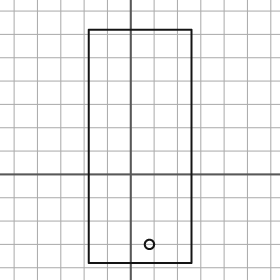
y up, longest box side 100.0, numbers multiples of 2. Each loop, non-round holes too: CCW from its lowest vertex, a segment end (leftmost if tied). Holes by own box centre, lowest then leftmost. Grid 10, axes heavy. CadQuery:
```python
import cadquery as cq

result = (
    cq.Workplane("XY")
    .moveTo(-18.0, -38.0)
    .lineTo(26.0, -38.0)
    .lineTo(26.0, 62.0)
    .lineTo(-18.0, 62.0)
    .close()
    .moveTo(8.0, -30.0)
    .circle(2.0)
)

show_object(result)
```